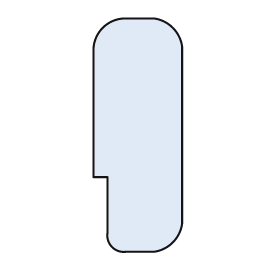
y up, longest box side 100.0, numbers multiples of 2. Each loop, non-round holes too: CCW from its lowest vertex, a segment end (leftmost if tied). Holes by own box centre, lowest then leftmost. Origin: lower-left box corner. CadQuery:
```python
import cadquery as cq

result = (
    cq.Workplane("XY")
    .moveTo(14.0, 0.0)
    .lineTo(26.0, 0.0)
    .threePointArc((34.0, 4.0), (38.0, 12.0))
    .lineTo(38.0, 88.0)
    .threePointArc((34.0, 96.0), (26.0, 100.0))
    .lineTo(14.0, 100.0)
    .threePointArc((4.0, 96.0), (0.0, 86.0))
    .lineTo(0.0, 32.0)
    .lineTo(6.0, 32.0)
    .lineTo(6.0, 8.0)
    .threePointArc((8.0, 2.0), (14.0, 0.0))
    .close()
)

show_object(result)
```